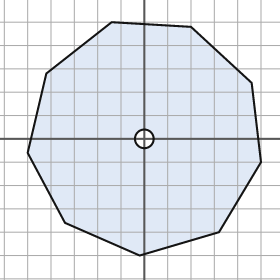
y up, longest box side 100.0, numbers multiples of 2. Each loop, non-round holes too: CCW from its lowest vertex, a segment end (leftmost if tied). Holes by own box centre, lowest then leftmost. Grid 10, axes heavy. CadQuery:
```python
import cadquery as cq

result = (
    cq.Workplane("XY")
    .moveTo(-2.0, -50.0)
    .lineTo(32.0, -40.0)
    .lineTo(50.0, -10.0)
    .lineTo(46.0, 24.0)
    .lineTo(20.0, 48.0)
    .lineTo(-14.0, 50.0)
    .lineTo(-42.0, 28.0)
    .lineTo(-50.0, -6.0)
    .lineTo(-34.0, -36.0)
    .close()
    .moveTo(0.0, 0.0)
    .circle(4.0)
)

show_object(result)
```